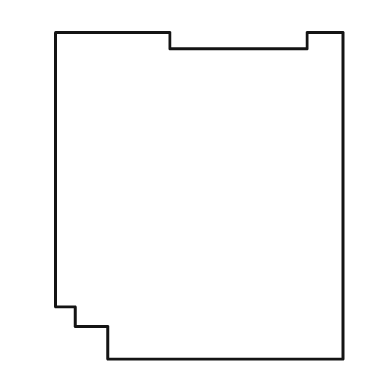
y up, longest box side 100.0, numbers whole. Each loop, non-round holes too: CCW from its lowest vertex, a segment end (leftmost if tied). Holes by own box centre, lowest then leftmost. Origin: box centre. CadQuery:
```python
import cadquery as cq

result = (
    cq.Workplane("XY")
    .moveTo(-28.0, -50.0)
    .lineTo(44.0, -50.0)
    .lineTo(44.0, 50.0)
    .lineTo(33.0, 50.0)
    .lineTo(33.0, 45.0)
    .lineTo(-9.0, 45.0)
    .lineTo(-9.0, 50.0)
    .lineTo(-44.0, 50.0)
    .lineTo(-44.0, -34.0)
    .lineTo(-38.0, -34.0)
    .lineTo(-38.0, -40.0)
    .lineTo(-28.0, -40.0)
    .close()
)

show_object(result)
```